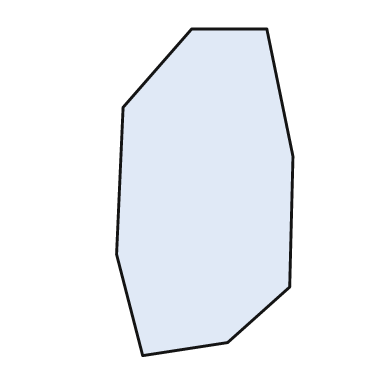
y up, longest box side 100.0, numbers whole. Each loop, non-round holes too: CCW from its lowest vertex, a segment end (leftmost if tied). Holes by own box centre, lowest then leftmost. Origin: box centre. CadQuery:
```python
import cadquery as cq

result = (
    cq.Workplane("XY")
    .moveTo(-19.0, -50.0)
    .lineTo(7.0, -46.0)
    .lineTo(26.0, -29.0)
    .lineTo(27.0, 11.0)
    .lineTo(19.0, 50.0)
    .lineTo(-4.0, 50.0)
    .lineTo(-25.0, 26.0)
    .lineTo(-27.0, -19.0)
    .close()
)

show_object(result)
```